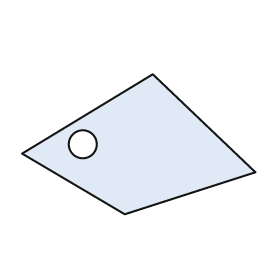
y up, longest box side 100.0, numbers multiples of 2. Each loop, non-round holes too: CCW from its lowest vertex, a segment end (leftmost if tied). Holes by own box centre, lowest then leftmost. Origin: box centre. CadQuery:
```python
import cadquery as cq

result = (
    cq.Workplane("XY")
    .moveTo(-6.0, -30.0)
    .lineTo(50.0, -12.0)
    .lineTo(6.0, 30.0)
    .lineTo(-50.0, -4.0)
    .close()
    .moveTo(-24.0, 0.0)
    .circle(6.0)
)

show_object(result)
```